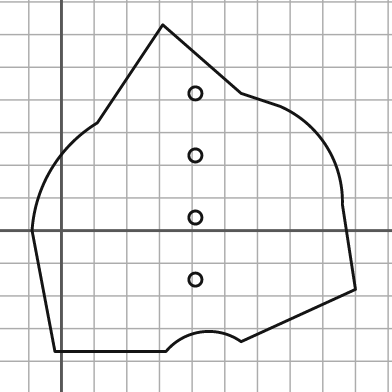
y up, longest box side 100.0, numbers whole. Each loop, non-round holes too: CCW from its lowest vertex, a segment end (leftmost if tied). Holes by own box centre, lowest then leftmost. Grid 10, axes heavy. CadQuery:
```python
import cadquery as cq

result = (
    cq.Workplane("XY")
    .moveTo(-2.0, -37.0)
    .lineTo(32.0, -37.0)
    .threePointArc((43.0, -31.0), (55.0, -34.0))
    .lineTo(90.0, -18.0)
    .lineTo(86.0, 8.0)
    .threePointArc((81.0, 26.0), (67.0, 38.0))
    .lineTo(55.0, 42.0)
    .lineTo(31.0, 63.0)
    .lineTo(11.0, 33.0)
    .threePointArc((-3.0, 19.0), (-9.0, 0.0))
    .close()
    .moveTo(41.0, -15.0)
    .circle(2.0)
    .moveTo(41.0, 4.0)
    .circle(2.0)
    .moveTo(41.0, 23.0)
    .circle(2.0)
    .moveTo(41.0, 42.0)
    .circle(2.0)
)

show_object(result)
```